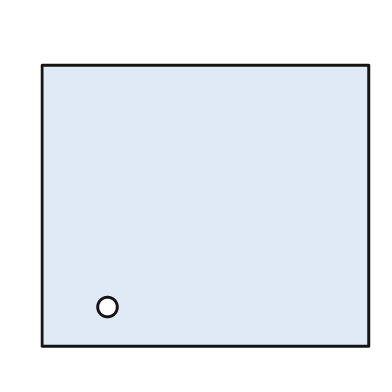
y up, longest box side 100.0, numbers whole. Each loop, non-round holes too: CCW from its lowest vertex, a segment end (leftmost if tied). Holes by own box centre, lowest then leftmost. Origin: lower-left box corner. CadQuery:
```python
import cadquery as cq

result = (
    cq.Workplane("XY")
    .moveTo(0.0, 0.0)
    .lineTo(100.0, 0.0)
    .lineTo(100.0, 86.0)
    .lineTo(0.0, 86.0)
    .close()
    .moveTo(20.0, 12.0)
    .circle(3.0)
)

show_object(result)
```